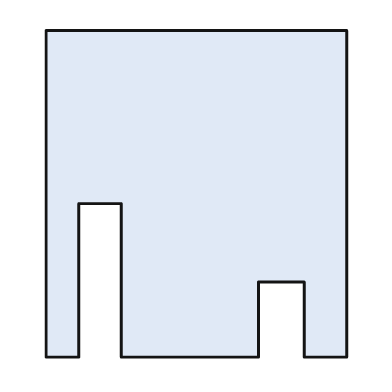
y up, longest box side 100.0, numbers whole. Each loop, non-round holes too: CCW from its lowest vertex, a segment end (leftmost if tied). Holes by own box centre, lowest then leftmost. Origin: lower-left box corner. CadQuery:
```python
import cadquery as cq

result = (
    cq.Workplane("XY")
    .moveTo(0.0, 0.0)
    .lineTo(10.0, 0.0)
    .lineTo(10.0, 47.0)
    .lineTo(23.0, 47.0)
    .lineTo(23.0, 0.0)
    .lineTo(65.0, 0.0)
    .lineTo(65.0, 23.0)
    .lineTo(79.0, 23.0)
    .lineTo(79.0, 0.0)
    .lineTo(92.0, 0.0)
    .lineTo(92.0, 100.0)
    .lineTo(0.0, 100.0)
    .close()
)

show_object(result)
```